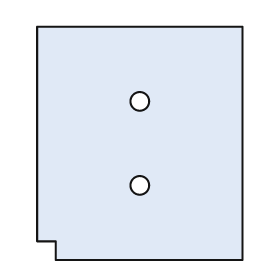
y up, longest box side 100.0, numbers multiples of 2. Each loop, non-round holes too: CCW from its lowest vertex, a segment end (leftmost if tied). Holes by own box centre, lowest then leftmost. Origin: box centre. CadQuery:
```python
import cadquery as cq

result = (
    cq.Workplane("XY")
    .moveTo(-36.0, -50.0)
    .lineTo(44.0, -50.0)
    .lineTo(44.0, 50.0)
    .lineTo(-44.0, 50.0)
    .lineTo(-44.0, -42.0)
    .lineTo(-36.0, -42.0)
    .close()
    .moveTo(0.0, -18.0)
    .circle(4.0)
    .moveTo(0.0, 18.0)
    .circle(4.0)
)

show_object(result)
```